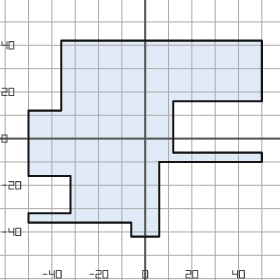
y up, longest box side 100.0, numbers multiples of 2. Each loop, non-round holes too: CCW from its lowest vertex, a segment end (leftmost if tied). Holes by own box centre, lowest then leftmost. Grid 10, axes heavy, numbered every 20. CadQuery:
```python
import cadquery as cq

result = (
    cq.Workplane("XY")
    .moveTo(-6.0, -42.0)
    .lineTo(6.0, -42.0)
    .lineTo(6.0, -10.0)
    .lineTo(50.0, -10.0)
    .lineTo(50.0, -6.0)
    .lineTo(12.0, -6.0)
    .lineTo(12.0, 16.0)
    .lineTo(50.0, 16.0)
    .lineTo(50.0, 42.0)
    .lineTo(-36.0, 42.0)
    .lineTo(-36.0, 12.0)
    .lineTo(-50.0, 12.0)
    .lineTo(-50.0, -16.0)
    .lineTo(-32.0, -16.0)
    .lineTo(-32.0, -32.0)
    .lineTo(-50.0, -32.0)
    .lineTo(-50.0, -36.0)
    .lineTo(-6.0, -36.0)
    .close()
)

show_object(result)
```